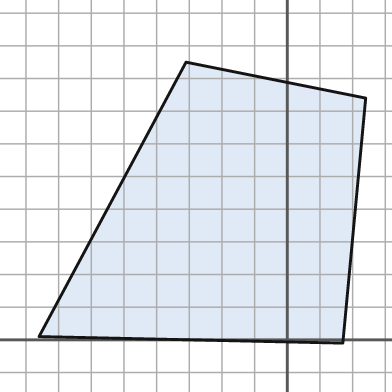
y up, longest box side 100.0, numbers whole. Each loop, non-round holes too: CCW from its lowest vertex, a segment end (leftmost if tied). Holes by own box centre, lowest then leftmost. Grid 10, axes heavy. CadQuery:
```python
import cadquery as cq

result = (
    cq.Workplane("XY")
    .moveTo(17.0, -1.0)
    .lineTo(24.0, 74.0)
    .lineTo(-31.0, 85.0)
    .lineTo(-76.0, 1.0)
    .close()
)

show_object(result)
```